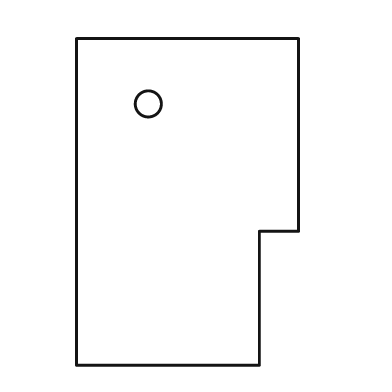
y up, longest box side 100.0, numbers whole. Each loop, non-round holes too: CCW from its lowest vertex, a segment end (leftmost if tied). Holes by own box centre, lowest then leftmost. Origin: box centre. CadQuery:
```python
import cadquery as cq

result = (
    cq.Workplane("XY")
    .moveTo(-34.0, -50.0)
    .lineTo(22.0, -50.0)
    .lineTo(22.0, -9.0)
    .lineTo(34.0, -9.0)
    .lineTo(34.0, 50.0)
    .lineTo(-34.0, 50.0)
    .close()
    .moveTo(-12.0, 30.0)
    .circle(4.0)
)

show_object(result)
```